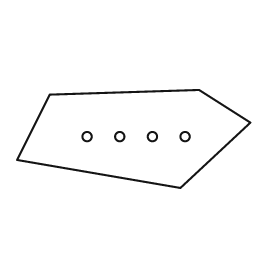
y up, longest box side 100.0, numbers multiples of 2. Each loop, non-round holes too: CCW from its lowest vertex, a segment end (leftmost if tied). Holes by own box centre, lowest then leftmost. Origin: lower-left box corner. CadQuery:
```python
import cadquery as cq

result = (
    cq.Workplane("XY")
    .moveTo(70.0, 0.0)
    .lineTo(100.0, 28.0)
    .lineTo(78.0, 42.0)
    .lineTo(14.0, 40.0)
    .lineTo(0.0, 12.0)
    .close()
    .moveTo(30.0, 22.0)
    .circle(2.0)
    .moveTo(44.0, 22.0)
    .circle(2.0)
    .moveTo(58.0, 22.0)
    .circle(2.0)
    .moveTo(72.0, 22.0)
    .circle(2.0)
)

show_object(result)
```